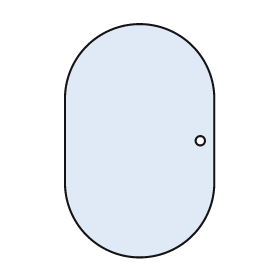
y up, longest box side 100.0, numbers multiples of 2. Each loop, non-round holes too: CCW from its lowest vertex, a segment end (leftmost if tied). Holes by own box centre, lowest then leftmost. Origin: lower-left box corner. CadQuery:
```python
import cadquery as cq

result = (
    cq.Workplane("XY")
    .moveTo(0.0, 32.0)
    .threePointArc((32.0, 0.0), (64.0, 32.0))
    .lineTo(64.0, 68.0)
    .threePointArc((32.0, 100.0), (0.0, 68.0))
    .close()
    .moveTo(58.0, 50.0)
    .circle(2.0)
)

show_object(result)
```